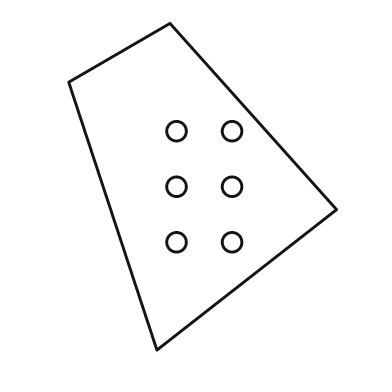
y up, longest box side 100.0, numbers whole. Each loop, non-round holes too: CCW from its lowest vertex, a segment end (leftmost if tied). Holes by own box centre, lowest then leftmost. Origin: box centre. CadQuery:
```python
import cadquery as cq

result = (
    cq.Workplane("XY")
    .moveTo(-14.0, -50.0)
    .lineTo(41.0, -7.0)
    .lineTo(-10.0, 50.0)
    .lineTo(-41.0, 32.0)
    .close()
    .moveTo(-8.0, -17.0)
    .circle(3.0)
    .moveTo(9.0, -17.0)
    .circle(3.0)
    .moveTo(-8.0, 0.0)
    .circle(3.0)
    .moveTo(9.0, 0.0)
    .circle(3.0)
    .moveTo(-8.0, 17.0)
    .circle(3.0)
    .moveTo(9.0, 17.0)
    .circle(3.0)
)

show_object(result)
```